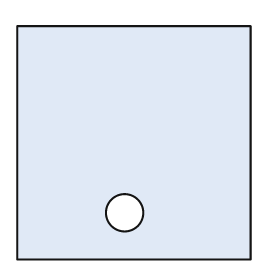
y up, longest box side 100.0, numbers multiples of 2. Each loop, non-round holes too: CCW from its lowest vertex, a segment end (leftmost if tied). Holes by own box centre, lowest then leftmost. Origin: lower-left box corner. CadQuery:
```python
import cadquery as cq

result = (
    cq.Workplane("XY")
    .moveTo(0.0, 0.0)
    .lineTo(100.0, 0.0)
    .lineTo(100.0, 100.0)
    .lineTo(0.0, 100.0)
    .close()
    .moveTo(46.0, 20.0)
    .circle(8.0)
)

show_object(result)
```